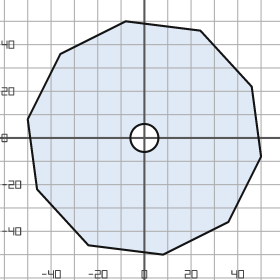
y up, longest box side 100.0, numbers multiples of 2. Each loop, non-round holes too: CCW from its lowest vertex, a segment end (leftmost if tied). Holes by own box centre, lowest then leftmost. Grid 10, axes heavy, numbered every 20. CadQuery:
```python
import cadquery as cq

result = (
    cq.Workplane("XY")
    .moveTo(8.0, -50.0)
    .lineTo(36.0, -36.0)
    .lineTo(50.0, -8.0)
    .lineTo(46.0, 22.0)
    .lineTo(24.0, 46.0)
    .lineTo(-8.0, 50.0)
    .lineTo(-36.0, 36.0)
    .lineTo(-50.0, 8.0)
    .lineTo(-46.0, -22.0)
    .lineTo(-24.0, -46.0)
    .close()
    .moveTo(0.0, 0.0)
    .circle(6.0)
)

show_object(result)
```